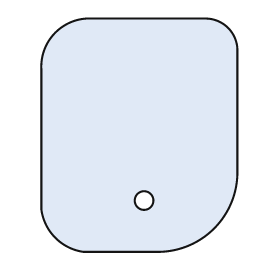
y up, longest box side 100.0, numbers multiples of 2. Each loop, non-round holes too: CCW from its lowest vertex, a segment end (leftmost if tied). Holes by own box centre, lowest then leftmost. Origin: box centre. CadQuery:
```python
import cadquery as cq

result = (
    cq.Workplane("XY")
    .moveTo(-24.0, -50.0)
    .lineTo(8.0, -50.0)
    .threePointArc((32.0, -40.0), (42.0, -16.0))
    .lineTo(42.0, 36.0)
    .threePointArc((38.0, 46.0), (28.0, 50.0))
    .lineTo(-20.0, 50.0)
    .threePointArc((-36.0, 44.0), (-42.0, 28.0))
    .lineTo(-42.0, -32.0)
    .threePointArc((-36.0, -44.0), (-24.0, -50.0))
    .close()
    .moveTo(2.0, -28.0)
    .circle(4.0)
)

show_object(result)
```